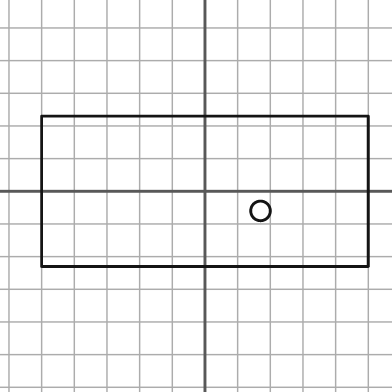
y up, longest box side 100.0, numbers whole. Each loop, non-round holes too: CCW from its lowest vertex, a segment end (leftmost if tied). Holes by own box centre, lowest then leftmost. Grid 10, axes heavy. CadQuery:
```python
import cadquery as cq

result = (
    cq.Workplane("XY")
    .moveTo(-50.0, -23.0)
    .lineTo(50.0, -23.0)
    .lineTo(50.0, 23.0)
    .lineTo(-50.0, 23.0)
    .close()
    .moveTo(17.0, -6.0)
    .circle(3.0)
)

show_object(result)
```